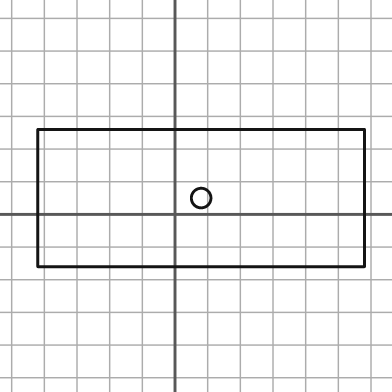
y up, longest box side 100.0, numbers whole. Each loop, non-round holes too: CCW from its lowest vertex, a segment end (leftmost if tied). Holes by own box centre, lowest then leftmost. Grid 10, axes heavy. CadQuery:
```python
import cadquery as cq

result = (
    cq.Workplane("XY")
    .moveTo(-42.0, -16.0)
    .lineTo(58.0, -16.0)
    .lineTo(58.0, 26.0)
    .lineTo(-42.0, 26.0)
    .close()
    .moveTo(8.0, 5.0)
    .circle(3.0)
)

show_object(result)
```